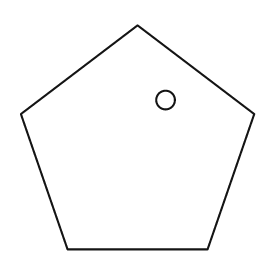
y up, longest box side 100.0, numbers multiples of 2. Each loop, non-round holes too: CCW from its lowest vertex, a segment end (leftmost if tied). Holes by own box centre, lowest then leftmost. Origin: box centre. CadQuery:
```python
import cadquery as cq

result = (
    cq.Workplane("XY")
    .moveTo(-30.0, -48.0)
    .lineTo(30.0, -48.0)
    .lineTo(50.0, 10.0)
    .lineTo(0.0, 48.0)
    .lineTo(-50.0, 10.0)
    .close()
    .moveTo(12.0, 16.0)
    .circle(4.0)
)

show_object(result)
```